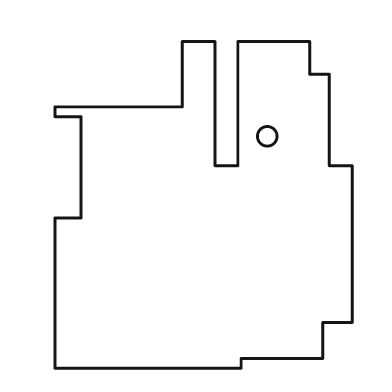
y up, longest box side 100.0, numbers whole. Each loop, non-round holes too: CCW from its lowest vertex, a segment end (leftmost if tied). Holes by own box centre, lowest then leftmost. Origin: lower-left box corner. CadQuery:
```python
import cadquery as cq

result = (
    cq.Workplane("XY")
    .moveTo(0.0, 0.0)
    .lineTo(57.0, 0.0)
    .lineTo(57.0, 3.0)
    .lineTo(82.0, 3.0)
    .lineTo(82.0, 14.0)
    .lineTo(91.0, 14.0)
    .lineTo(91.0, 62.0)
    .lineTo(84.0, 62.0)
    .lineTo(84.0, 90.0)
    .lineTo(78.0, 90.0)
    .lineTo(78.0, 100.0)
    .lineTo(56.0, 100.0)
    .lineTo(56.0, 62.0)
    .lineTo(49.0, 62.0)
    .lineTo(49.0, 100.0)
    .lineTo(39.0, 100.0)
    .lineTo(39.0, 80.0)
    .lineTo(0.0, 80.0)
    .lineTo(0.0, 77.0)
    .lineTo(8.0, 77.0)
    .lineTo(8.0, 46.0)
    .lineTo(0.0, 46.0)
    .close()
    .moveTo(65.0, 71.0)
    .circle(3.0)
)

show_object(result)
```